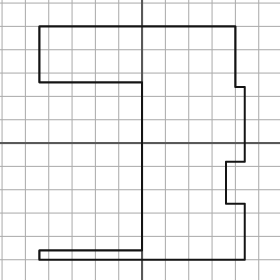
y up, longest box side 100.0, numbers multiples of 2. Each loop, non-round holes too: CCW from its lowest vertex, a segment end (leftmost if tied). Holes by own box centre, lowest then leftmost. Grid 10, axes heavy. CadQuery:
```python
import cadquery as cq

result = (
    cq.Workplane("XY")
    .moveTo(-44.0, -50.0)
    .lineTo(44.0, -50.0)
    .lineTo(44.0, -26.0)
    .lineTo(36.0, -26.0)
    .lineTo(36.0, -8.0)
    .lineTo(44.0, -8.0)
    .lineTo(44.0, 24.0)
    .lineTo(40.0, 24.0)
    .lineTo(40.0, 50.0)
    .lineTo(-44.0, 50.0)
    .lineTo(-44.0, 26.0)
    .lineTo(0.0, 26.0)
    .lineTo(0.0, -46.0)
    .lineTo(-44.0, -46.0)
    .close()
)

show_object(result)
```